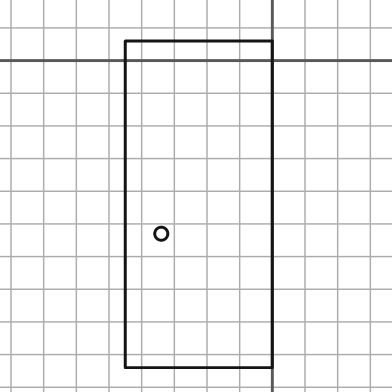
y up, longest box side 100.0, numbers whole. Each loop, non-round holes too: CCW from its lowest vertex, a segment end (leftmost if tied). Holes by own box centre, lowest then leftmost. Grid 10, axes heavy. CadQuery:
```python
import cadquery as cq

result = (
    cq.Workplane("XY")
    .moveTo(-45.0, -94.0)
    .lineTo(0.0, -94.0)
    .lineTo(0.0, 6.0)
    .lineTo(-45.0, 6.0)
    .close()
    .moveTo(-34.0, -53.0)
    .circle(2.0)
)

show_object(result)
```